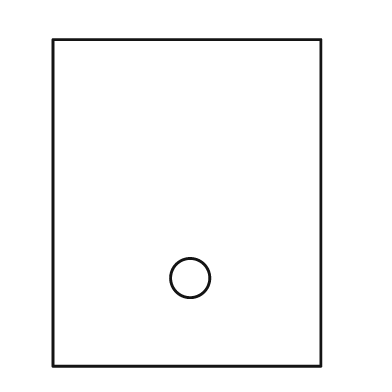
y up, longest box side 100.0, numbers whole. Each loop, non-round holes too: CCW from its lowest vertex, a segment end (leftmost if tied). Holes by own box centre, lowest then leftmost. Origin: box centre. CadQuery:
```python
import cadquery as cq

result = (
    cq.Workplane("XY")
    .moveTo(-41.0, -50.0)
    .lineTo(41.0, -50.0)
    .lineTo(41.0, 50.0)
    .lineTo(-41.0, 50.0)
    .close()
    .moveTo(1.0, -23.0)
    .circle(6.0)
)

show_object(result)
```